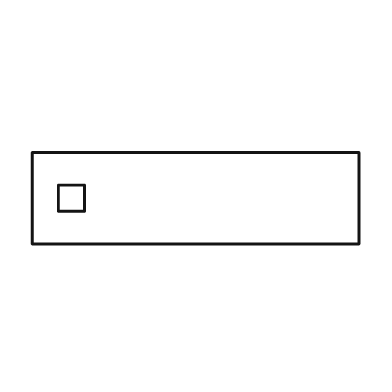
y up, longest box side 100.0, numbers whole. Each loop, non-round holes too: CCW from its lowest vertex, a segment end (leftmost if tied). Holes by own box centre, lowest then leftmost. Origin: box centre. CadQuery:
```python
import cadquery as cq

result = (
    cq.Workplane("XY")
    .moveTo(-50.0, -14.0)
    .lineTo(50.0, -14.0)
    .lineTo(50.0, 14.0)
    .lineTo(-50.0, 14.0)
    .close()
    .moveTo(-42.0, -4.0)
    .lineTo(-34.0, -4.0)
    .lineTo(-34.0, 4.0)
    .lineTo(-42.0, 4.0)
    .close()
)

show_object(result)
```